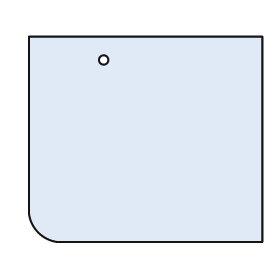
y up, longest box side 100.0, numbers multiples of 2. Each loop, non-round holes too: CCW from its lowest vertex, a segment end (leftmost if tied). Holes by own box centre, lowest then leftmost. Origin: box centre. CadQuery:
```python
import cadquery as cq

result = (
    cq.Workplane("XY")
    .moveTo(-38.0, -44.0)
    .lineTo(50.0, -44.0)
    .lineTo(50.0, 44.0)
    .lineTo(-50.0, 44.0)
    .lineTo(-50.0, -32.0)
    .threePointArc((-46.0, -40.0), (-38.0, -44.0))
    .close()
    .moveTo(-18.0, 34.0)
    .circle(2.0)
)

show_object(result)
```